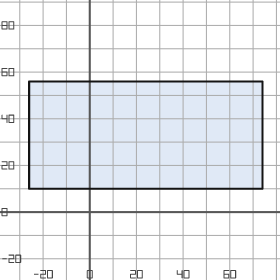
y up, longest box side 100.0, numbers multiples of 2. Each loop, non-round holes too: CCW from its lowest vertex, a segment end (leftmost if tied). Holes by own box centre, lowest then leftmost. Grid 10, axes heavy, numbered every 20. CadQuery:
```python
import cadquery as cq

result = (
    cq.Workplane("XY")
    .moveTo(-26.0, 10.0)
    .lineTo(74.0, 10.0)
    .lineTo(74.0, 56.0)
    .lineTo(-26.0, 56.0)
    .close()
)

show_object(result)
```